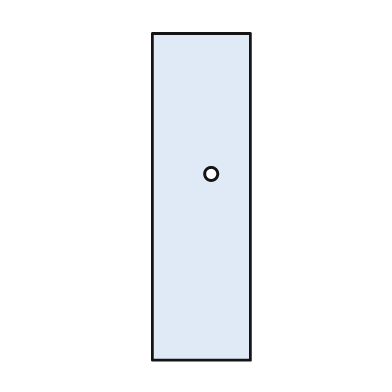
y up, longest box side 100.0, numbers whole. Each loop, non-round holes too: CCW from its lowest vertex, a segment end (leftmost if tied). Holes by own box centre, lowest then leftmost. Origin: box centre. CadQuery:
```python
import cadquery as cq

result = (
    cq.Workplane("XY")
    .moveTo(-15.0, -50.0)
    .lineTo(15.0, -50.0)
    .lineTo(15.0, 50.0)
    .lineTo(-15.0, 50.0)
    .close()
    .moveTo(3.0, 7.0)
    .circle(2.0)
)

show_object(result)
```